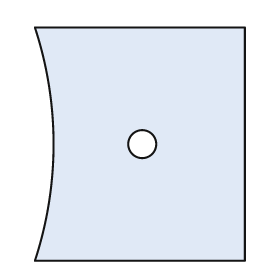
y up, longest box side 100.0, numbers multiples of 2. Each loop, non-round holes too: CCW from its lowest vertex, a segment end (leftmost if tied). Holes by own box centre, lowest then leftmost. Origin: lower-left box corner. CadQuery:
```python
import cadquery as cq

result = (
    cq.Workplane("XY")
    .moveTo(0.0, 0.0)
    .lineTo(90.0, 0.0)
    .lineTo(90.0, 100.0)
    .lineTo(0.0, 100.0)
    .threePointArc((8.0, 50.0), (0.0, 0.0))
    .close()
    .moveTo(46.0, 50.0)
    .circle(6.0)
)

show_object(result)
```